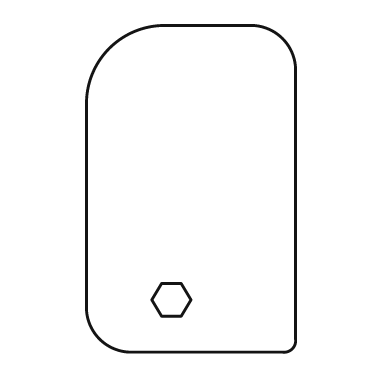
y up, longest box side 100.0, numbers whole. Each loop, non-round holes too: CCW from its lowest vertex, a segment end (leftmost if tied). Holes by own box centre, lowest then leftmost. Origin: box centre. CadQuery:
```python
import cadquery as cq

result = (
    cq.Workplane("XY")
    .moveTo(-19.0, -50.0)
    .lineTo(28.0, -50.0)
    .threePointArc((31.0, -49.0), (32.0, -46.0))
    .lineTo(32.0, 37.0)
    .threePointArc((28.0, 46.0), (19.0, 50.0))
    .lineTo(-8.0, 50.0)
    .threePointArc((-25.0, 43.0), (-32.0, 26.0))
    .lineTo(-32.0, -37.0)
    .threePointArc((-28.0, -46.0), (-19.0, -50.0))
    .close()
    .moveTo(-9.0, -39.0)
    .lineTo(-3.0, -39.0)
    .lineTo(0.0, -34.0)
    .lineTo(-3.0, -29.0)
    .lineTo(-9.0, -29.0)
    .lineTo(-12.0, -34.0)
    .close()
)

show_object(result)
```